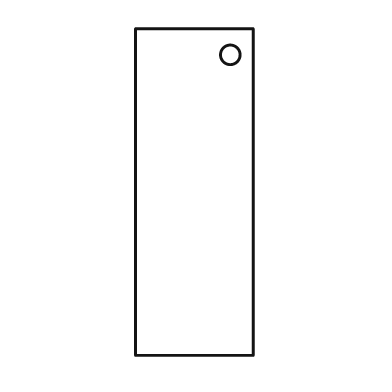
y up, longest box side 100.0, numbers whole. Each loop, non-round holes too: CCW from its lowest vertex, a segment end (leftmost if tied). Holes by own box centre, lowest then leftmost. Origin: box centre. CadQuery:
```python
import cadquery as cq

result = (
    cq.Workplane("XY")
    .moveTo(-18.0, -50.0)
    .lineTo(18.0, -50.0)
    .lineTo(18.0, 50.0)
    .lineTo(-18.0, 50.0)
    .close()
    .moveTo(11.0, 42.0)
    .circle(3.0)
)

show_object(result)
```